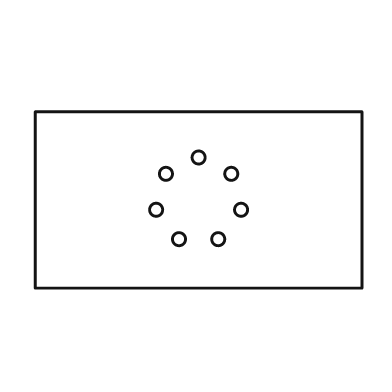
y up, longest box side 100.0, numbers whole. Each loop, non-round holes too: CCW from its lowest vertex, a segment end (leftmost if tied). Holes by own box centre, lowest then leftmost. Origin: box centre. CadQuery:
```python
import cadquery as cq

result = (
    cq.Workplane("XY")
    .moveTo(-50.0, -27.0)
    .lineTo(50.0, -27.0)
    .lineTo(50.0, 27.0)
    .lineTo(-50.0, 27.0)
    .close()
    .moveTo(-6.0, -12.0)
    .circle(2.0)
    .moveTo(6.0, -12.0)
    .circle(2.0)
    .moveTo(-13.0, -3.0)
    .circle(2.0)
    .moveTo(13.0, -3.0)
    .circle(2.0)
    .moveTo(-10.0, 8.0)
    .circle(2.0)
    .moveTo(10.0, 8.0)
    .circle(2.0)
    .moveTo(0.0, 13.0)
    .circle(2.0)
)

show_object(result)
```